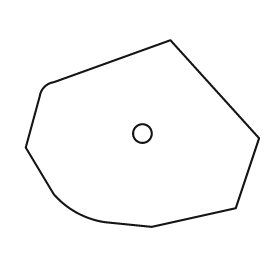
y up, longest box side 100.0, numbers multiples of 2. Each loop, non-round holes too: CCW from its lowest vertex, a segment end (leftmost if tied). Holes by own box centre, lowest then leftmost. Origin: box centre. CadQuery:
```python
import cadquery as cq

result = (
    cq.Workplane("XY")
    .moveTo(4.0, -40.0)
    .lineTo(40.0, -32.0)
    .lineTo(50.0, -2.0)
    .lineTo(12.0, 40.0)
    .lineTo(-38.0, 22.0)
    .threePointArc((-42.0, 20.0), (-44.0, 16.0))
    .lineTo(-50.0, -6.0)
    .lineTo(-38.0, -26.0)
    .threePointArc((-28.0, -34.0), (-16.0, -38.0))
    .close()
    .moveTo(0.0, 0.0)
    .circle(4.0)
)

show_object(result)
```